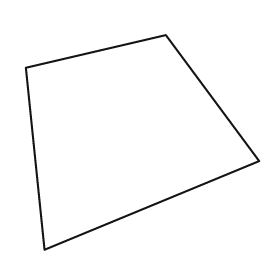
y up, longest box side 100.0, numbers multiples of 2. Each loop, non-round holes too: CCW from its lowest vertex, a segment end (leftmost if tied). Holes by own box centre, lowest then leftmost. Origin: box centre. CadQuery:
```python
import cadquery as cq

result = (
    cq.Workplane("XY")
    .moveTo(-42.0, -46.0)
    .lineTo(50.0, -8.0)
    .lineTo(10.0, 46.0)
    .lineTo(-50.0, 32.0)
    .close()
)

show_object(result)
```